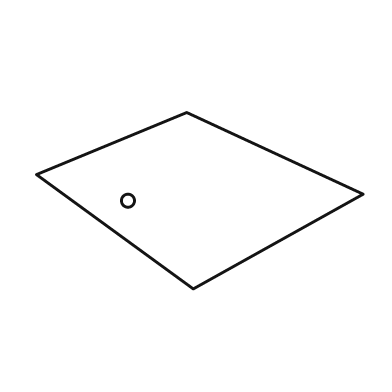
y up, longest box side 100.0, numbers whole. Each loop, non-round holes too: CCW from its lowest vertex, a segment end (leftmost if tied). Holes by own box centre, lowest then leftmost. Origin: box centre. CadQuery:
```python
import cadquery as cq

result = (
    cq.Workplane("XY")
    .moveTo(-2.0, -27.0)
    .lineTo(50.0, 2.0)
    .lineTo(-4.0, 27.0)
    .lineTo(-50.0, 8.0)
    .close()
    .moveTo(-22.0, 0.0)
    .circle(2.0)
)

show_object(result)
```